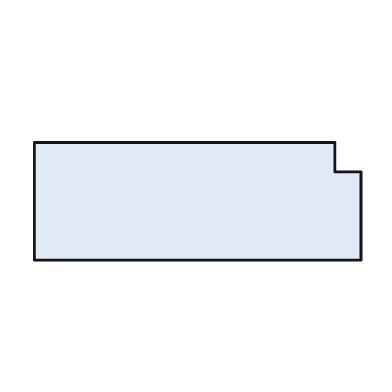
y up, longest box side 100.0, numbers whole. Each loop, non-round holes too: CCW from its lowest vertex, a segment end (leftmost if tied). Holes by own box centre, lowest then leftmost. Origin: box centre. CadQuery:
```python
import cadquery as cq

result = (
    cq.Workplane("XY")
    .moveTo(-50.0, -18.0)
    .lineTo(50.0, -18.0)
    .lineTo(50.0, 9.0)
    .lineTo(42.0, 9.0)
    .lineTo(42.0, 18.0)
    .lineTo(-50.0, 18.0)
    .close()
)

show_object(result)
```